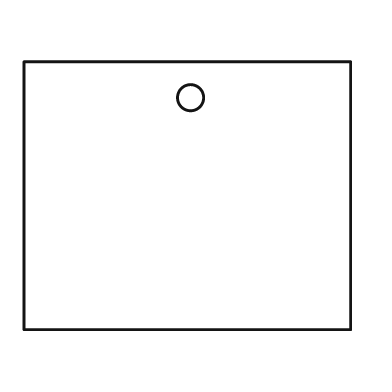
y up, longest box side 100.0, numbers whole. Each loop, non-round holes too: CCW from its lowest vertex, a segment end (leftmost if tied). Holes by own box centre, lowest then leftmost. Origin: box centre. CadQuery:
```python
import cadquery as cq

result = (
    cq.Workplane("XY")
    .moveTo(-50.0, -41.0)
    .lineTo(50.0, -41.0)
    .lineTo(50.0, 41.0)
    .lineTo(-50.0, 41.0)
    .close()
    .moveTo(1.0, 30.0)
    .circle(4.0)
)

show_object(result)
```